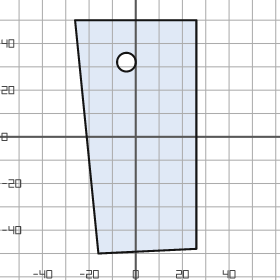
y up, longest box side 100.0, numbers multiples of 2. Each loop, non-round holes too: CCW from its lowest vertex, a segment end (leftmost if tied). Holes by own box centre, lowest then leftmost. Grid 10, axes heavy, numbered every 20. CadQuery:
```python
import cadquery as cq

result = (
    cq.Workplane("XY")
    .moveTo(-16.0, -50.0)
    .lineTo(26.0, -48.0)
    .lineTo(26.0, 50.0)
    .lineTo(-26.0, 50.0)
    .close()
    .moveTo(-4.0, 32.0)
    .circle(4.0)
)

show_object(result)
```